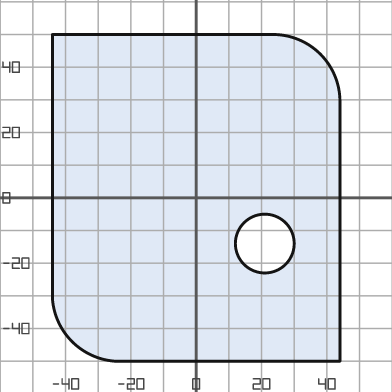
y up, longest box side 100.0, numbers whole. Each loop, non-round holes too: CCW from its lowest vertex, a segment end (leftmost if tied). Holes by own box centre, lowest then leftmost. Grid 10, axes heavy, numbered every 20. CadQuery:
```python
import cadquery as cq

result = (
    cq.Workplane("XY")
    .moveTo(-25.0, -50.0)
    .lineTo(44.0, -50.0)
    .lineTo(44.0, 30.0)
    .threePointArc((38.0, 44.0), (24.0, 50.0))
    .lineTo(-44.0, 50.0)
    .lineTo(-44.0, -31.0)
    .threePointArc((-38.0, -44.0), (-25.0, -50.0))
    .close()
    .moveTo(21.0, -14.0)
    .circle(9.0)
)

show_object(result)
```